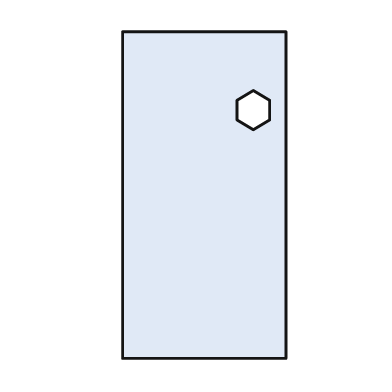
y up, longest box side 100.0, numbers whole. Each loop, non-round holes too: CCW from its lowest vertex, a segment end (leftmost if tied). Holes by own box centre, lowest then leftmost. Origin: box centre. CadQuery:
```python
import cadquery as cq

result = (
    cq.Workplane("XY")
    .moveTo(-25.0, -50.0)
    .lineTo(25.0, -50.0)
    .lineTo(25.0, 50.0)
    .lineTo(-25.0, 50.0)
    .close()
    .moveTo(15.0, 20.0)
    .lineTo(20.0, 23.0)
    .lineTo(20.0, 29.0)
    .lineTo(15.0, 32.0)
    .lineTo(10.0, 29.0)
    .lineTo(10.0, 23.0)
    .close()
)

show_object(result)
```